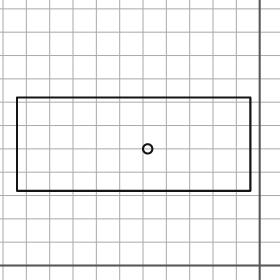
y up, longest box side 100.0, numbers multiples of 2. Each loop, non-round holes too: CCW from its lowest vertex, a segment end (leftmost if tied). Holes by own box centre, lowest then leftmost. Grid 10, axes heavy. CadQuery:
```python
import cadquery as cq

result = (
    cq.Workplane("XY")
    .moveTo(-104.0, 32.0)
    .lineTo(-4.0, 32.0)
    .lineTo(-4.0, 72.0)
    .lineTo(-104.0, 72.0)
    .close()
    .moveTo(-48.0, 50.0)
    .circle(2.0)
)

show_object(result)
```